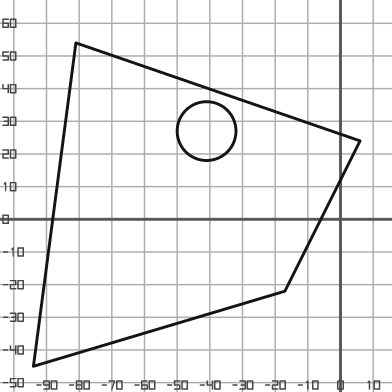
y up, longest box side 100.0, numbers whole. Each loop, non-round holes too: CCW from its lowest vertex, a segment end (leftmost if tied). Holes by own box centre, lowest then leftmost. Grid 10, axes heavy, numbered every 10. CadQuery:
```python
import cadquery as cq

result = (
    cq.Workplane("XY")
    .moveTo(-94.0, -45.0)
    .lineTo(-17.0, -22.0)
    .lineTo(6.0, 24.0)
    .lineTo(-81.0, 54.0)
    .close()
    .moveTo(-41.0, 27.0)
    .circle(9.0)
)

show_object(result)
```